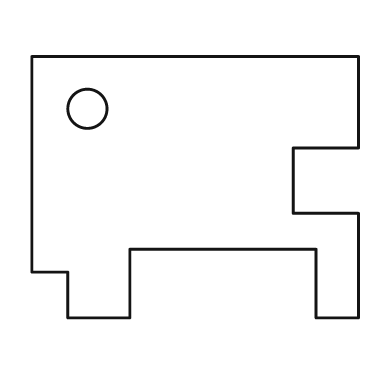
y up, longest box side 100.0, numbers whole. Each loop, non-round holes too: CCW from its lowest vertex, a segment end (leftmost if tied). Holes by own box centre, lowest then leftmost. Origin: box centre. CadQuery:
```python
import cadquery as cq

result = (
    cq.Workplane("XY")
    .moveTo(-39.0, -40.0)
    .lineTo(-20.0, -40.0)
    .lineTo(-20.0, -19.0)
    .lineTo(37.0, -19.0)
    .lineTo(37.0, -40.0)
    .lineTo(50.0, -40.0)
    .lineTo(50.0, -8.0)
    .lineTo(30.0, -8.0)
    .lineTo(30.0, 12.0)
    .lineTo(50.0, 12.0)
    .lineTo(50.0, 40.0)
    .lineTo(-50.0, 40.0)
    .lineTo(-50.0, -26.0)
    .lineTo(-39.0, -26.0)
    .close()
    .moveTo(-33.0, 24.0)
    .circle(6.0)
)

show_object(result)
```